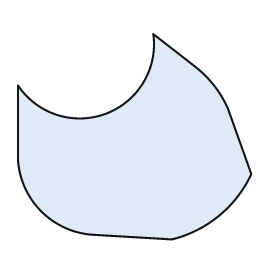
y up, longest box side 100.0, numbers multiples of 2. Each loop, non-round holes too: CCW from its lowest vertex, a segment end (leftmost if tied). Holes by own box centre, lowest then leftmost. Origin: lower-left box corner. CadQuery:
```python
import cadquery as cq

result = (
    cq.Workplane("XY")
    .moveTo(66.0, 0.0)
    .threePointArc((86.0, 10.0), (100.0, 28.0))
    .lineTo(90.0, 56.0)
    .threePointArc((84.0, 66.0), (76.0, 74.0))
    .lineTo(58.0, 88.0)
    .threePointArc((38.0, 54.0), (0.0, 66.0))
    .lineTo(0.0, 34.0)
    .threePointArc((10.0, 12.0), (32.0, 2.0))
    .close()
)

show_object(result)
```